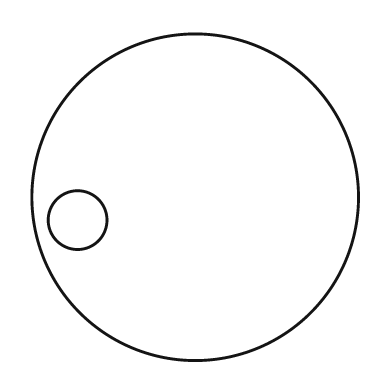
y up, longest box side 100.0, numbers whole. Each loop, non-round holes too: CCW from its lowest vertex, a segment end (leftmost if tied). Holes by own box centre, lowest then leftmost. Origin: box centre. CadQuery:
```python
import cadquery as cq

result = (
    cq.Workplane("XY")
    .moveTo(0.0, 0.0)
    .circle(50.0)
    .moveTo(-36.0, -7.0)
    .circle(9.0)
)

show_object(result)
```